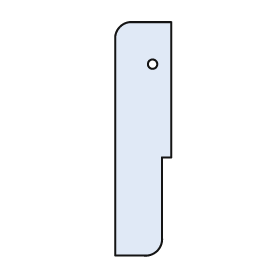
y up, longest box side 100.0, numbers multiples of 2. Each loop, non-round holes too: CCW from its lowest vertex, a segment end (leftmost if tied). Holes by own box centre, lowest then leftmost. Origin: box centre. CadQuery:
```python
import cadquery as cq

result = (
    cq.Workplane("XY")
    .moveTo(-12.0, -50.0)
    .lineTo(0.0, -50.0)
    .threePointArc((6.0, -48.0), (8.0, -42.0))
    .lineTo(8.0, -8.0)
    .lineTo(12.0, -8.0)
    .lineTo(12.0, 50.0)
    .lineTo(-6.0, 50.0)
    .threePointArc((-10.0, 48.0), (-12.0, 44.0))
    .close()
    .moveTo(4.0, 32.0)
    .circle(2.0)
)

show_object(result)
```